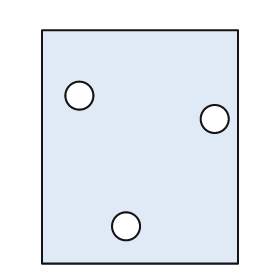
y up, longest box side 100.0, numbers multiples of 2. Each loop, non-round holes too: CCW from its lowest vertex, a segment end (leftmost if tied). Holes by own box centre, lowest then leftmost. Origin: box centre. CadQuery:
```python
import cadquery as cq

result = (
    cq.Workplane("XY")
    .moveTo(-42.0, -50.0)
    .lineTo(42.0, -50.0)
    .lineTo(42.0, 50.0)
    .lineTo(-42.0, 50.0)
    .close()
    .moveTo(-6.0, -34.0)
    .circle(6.0)
    .moveTo(32.0, 12.0)
    .circle(6.0)
    .moveTo(-26.0, 22.0)
    .circle(6.0)
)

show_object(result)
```